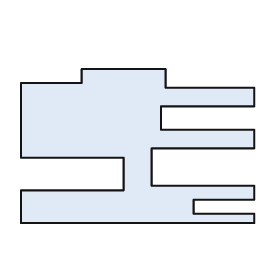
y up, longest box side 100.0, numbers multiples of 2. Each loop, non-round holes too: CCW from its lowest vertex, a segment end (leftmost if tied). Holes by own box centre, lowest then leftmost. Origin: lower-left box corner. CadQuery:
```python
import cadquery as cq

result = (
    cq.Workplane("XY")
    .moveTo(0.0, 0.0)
    .lineTo(100.0, 0.0)
    .lineTo(100.0, 4.0)
    .lineTo(74.0, 4.0)
    .lineTo(74.0, 10.0)
    .lineTo(100.0, 10.0)
    .lineTo(100.0, 16.0)
    .lineTo(56.0, 16.0)
    .lineTo(56.0, 32.0)
    .lineTo(100.0, 32.0)
    .lineTo(100.0, 40.0)
    .lineTo(60.0, 40.0)
    .lineTo(60.0, 50.0)
    .lineTo(100.0, 50.0)
    .lineTo(100.0, 58.0)
    .lineTo(62.0, 58.0)
    .lineTo(62.0, 66.0)
    .lineTo(26.0, 66.0)
    .lineTo(26.0, 60.0)
    .lineTo(0.0, 60.0)
    .lineTo(0.0, 28.0)
    .lineTo(44.0, 28.0)
    .lineTo(44.0, 14.0)
    .lineTo(0.0, 14.0)
    .close()
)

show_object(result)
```